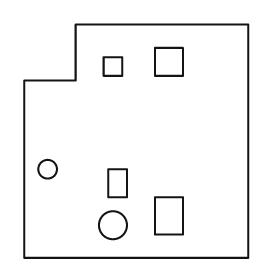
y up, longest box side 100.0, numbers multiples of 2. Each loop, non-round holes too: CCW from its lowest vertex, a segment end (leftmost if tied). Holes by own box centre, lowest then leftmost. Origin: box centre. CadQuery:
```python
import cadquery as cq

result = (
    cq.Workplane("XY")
    .moveTo(-48.0, -50.0)
    .lineTo(48.0, -50.0)
    .lineTo(48.0, 50.0)
    .lineTo(-26.0, 50.0)
    .lineTo(-26.0, 26.0)
    .lineTo(-48.0, 26.0)
    .close()
    .moveTo(-10.0, -36.0)
    .circle(6.0)
    .moveTo(8.0, -40.0)
    .lineTo(20.0, -40.0)
    .lineTo(20.0, -24.0)
    .lineTo(8.0, -24.0)
    .close()
    .moveTo(-12.0, -24.0)
    .lineTo(-4.0, -24.0)
    .lineTo(-4.0, -12.0)
    .lineTo(-12.0, -12.0)
    .close()
    .moveTo(-38.0, -12.0)
    .circle(4.0)
    .moveTo(-14.0, 28.0)
    .lineTo(-6.0, 28.0)
    .lineTo(-6.0, 36.0)
    .lineTo(-14.0, 36.0)
    .close()
    .moveTo(8.0, 28.0)
    .lineTo(20.0, 28.0)
    .lineTo(20.0, 40.0)
    .lineTo(8.0, 40.0)
    .close()
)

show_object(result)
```